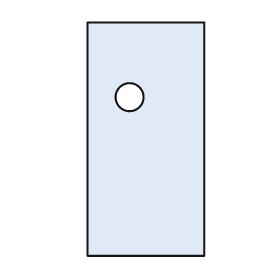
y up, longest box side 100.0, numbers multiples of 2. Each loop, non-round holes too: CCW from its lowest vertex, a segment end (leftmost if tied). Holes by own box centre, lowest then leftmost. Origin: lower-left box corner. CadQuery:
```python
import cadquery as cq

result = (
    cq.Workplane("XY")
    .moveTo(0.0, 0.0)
    .lineTo(50.0, 0.0)
    .lineTo(50.0, 100.0)
    .lineTo(0.0, 100.0)
    .close()
    .moveTo(18.0, 68.0)
    .circle(6.0)
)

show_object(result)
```